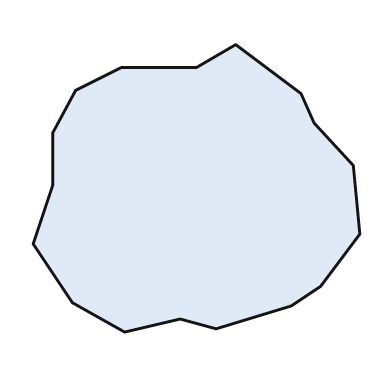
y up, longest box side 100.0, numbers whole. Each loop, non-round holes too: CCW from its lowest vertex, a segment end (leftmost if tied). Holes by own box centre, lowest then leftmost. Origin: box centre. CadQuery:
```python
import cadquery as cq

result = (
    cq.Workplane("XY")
    .moveTo(-22.0, -44.0)
    .lineTo(-5.0, -40.0)
    .lineTo(6.0, -43.0)
    .lineTo(29.0, -36.0)
    .lineTo(38.0, -30.0)
    .lineTo(50.0, -14.0)
    .lineTo(48.0, 7.0)
    .lineTo(36.0, 20.0)
    .lineTo(32.0, 29.0)
    .lineTo(12.0, 44.0)
    .lineTo(0.0, 37.0)
    .lineTo(-23.0, 37.0)
    .lineTo(-37.0, 30.0)
    .lineTo(-44.0, 17.0)
    .lineTo(-44.0, 1.0)
    .lineTo(-50.0, -17.0)
    .lineTo(-38.0, -35.0)
    .close()
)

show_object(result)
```